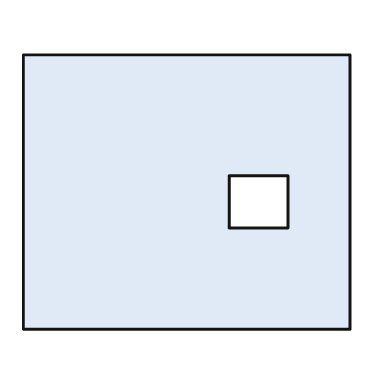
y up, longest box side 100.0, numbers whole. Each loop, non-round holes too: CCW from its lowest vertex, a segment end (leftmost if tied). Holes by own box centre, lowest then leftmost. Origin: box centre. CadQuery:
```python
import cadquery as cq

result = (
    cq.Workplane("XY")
    .moveTo(-50.0, -42.0)
    .lineTo(50.0, -42.0)
    .lineTo(50.0, 42.0)
    .lineTo(-50.0, 42.0)
    .close()
    .moveTo(13.0, -11.0)
    .lineTo(31.0, -11.0)
    .lineTo(31.0, 5.0)
    .lineTo(13.0, 5.0)
    .close()
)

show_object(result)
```